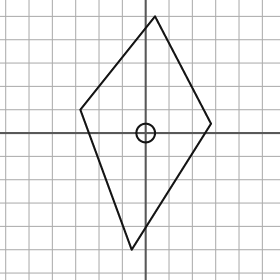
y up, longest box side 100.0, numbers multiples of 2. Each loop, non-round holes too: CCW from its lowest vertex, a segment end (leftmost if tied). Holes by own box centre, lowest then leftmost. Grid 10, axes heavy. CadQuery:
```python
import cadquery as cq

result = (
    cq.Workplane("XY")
    .moveTo(-6.0, -50.0)
    .lineTo(28.0, 4.0)
    .lineTo(4.0, 50.0)
    .lineTo(-28.0, 10.0)
    .close()
    .moveTo(0.0, 0.0)
    .circle(4.0)
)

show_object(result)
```